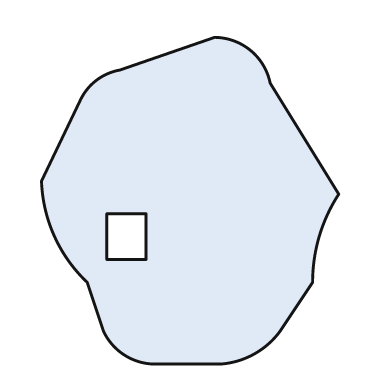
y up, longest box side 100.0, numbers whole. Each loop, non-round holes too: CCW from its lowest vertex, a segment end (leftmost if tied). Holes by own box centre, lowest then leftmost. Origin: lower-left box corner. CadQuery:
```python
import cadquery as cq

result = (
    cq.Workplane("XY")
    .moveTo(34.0, 0.0)
    .lineTo(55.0, 0.0)
    .threePointArc((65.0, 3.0), (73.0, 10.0))
    .lineTo(83.0, 25.0)
    .threePointArc((85.0, 39.0), (91.0, 52.0))
    .lineTo(70.0, 86.0)
    .threePointArc((64.0, 96.0), (53.0, 100.0))
    .lineTo(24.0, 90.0)
    .threePointArc((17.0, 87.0), (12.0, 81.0))
    .lineTo(0.0, 56.0)
    .threePointArc((4.0, 39.0), (14.0, 25.0))
    .lineTo(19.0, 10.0)
    .threePointArc((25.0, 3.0), (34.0, 0.0))
    .close()
    .moveTo(20.0, 32.0)
    .lineTo(32.0, 32.0)
    .lineTo(32.0, 46.0)
    .lineTo(20.0, 46.0)
    .close()
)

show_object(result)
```